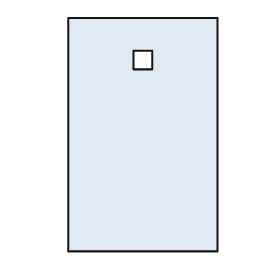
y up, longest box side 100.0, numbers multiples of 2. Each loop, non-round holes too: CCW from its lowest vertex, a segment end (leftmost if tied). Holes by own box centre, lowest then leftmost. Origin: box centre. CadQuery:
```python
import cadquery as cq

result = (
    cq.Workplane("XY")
    .moveTo(-32.0, -50.0)
    .lineTo(32.0, -50.0)
    .lineTo(32.0, 50.0)
    .lineTo(-32.0, 50.0)
    .close()
    .moveTo(-4.0, 28.0)
    .lineTo(4.0, 28.0)
    .lineTo(4.0, 36.0)
    .lineTo(-4.0, 36.0)
    .close()
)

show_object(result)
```